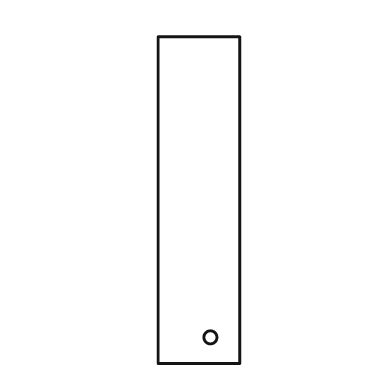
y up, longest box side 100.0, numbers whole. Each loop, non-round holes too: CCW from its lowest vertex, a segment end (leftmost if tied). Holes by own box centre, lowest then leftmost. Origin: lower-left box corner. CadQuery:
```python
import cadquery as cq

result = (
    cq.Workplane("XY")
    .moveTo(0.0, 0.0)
    .lineTo(25.0, 0.0)
    .lineTo(25.0, 100.0)
    .lineTo(0.0, 100.0)
    .close()
    .moveTo(16.0, 8.0)
    .circle(2.0)
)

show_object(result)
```